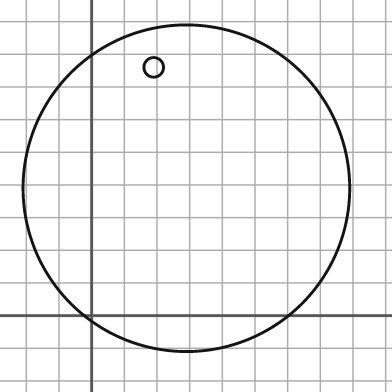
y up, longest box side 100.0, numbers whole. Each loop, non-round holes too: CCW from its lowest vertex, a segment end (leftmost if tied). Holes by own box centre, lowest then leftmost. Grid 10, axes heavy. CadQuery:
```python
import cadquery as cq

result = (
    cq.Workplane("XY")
    .moveTo(29.0, 39.0)
    .circle(50.0)
    .moveTo(19.0, 76.0)
    .circle(3.0)
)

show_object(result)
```